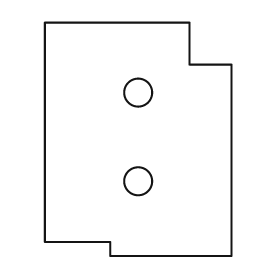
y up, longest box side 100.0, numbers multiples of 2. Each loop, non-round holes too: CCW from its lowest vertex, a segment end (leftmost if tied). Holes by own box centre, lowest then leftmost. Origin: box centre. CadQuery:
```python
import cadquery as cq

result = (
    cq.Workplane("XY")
    .moveTo(-12.0, -50.0)
    .lineTo(40.0, -50.0)
    .lineTo(40.0, 32.0)
    .lineTo(22.0, 32.0)
    .lineTo(22.0, 50.0)
    .lineTo(-40.0, 50.0)
    .lineTo(-40.0, -44.0)
    .lineTo(-12.0, -44.0)
    .close()
    .moveTo(0.0, -18.0)
    .circle(6.0)
    .moveTo(0.0, 20.0)
    .circle(6.0)
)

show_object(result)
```